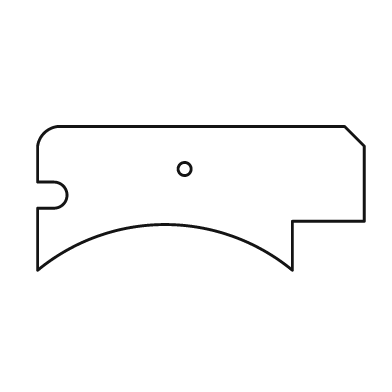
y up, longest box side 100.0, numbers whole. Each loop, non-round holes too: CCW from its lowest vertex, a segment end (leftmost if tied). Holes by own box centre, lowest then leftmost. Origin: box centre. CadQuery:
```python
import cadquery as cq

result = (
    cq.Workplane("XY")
    .moveTo(-50.0, -22.0)
    .threePointArc((-11.0, -8.0), (28.0, -22.0))
    .lineTo(28.0, -7.0)
    .lineTo(50.0, -7.0)
    .lineTo(50.0, 16.0)
    .lineTo(44.0, 22.0)
    .lineTo(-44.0, 22.0)
    .threePointArc((-48.0, 20.0), (-50.0, 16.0))
    .lineTo(-50.0, 5.0)
    .lineTo(-45.0, 5.0)
    .threePointArc((-41.0, 1.0), (-45.0, -3.0))
    .lineTo(-50.0, -3.0)
    .close()
    .moveTo(-5.0, 9.0)
    .circle(2.0)
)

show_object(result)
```